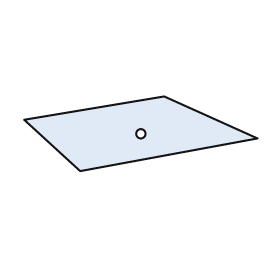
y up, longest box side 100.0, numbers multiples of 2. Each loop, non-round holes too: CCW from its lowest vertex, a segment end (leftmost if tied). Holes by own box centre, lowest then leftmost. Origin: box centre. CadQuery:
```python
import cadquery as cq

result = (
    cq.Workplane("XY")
    .moveTo(-26.0, -16.0)
    .lineTo(50.0, -2.0)
    .lineTo(10.0, 16.0)
    .lineTo(-50.0, 6.0)
    .close()
    .moveTo(0.0, 0.0)
    .circle(2.0)
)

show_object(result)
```